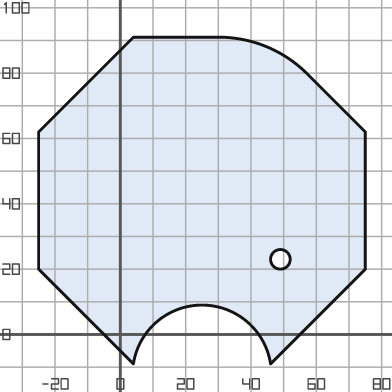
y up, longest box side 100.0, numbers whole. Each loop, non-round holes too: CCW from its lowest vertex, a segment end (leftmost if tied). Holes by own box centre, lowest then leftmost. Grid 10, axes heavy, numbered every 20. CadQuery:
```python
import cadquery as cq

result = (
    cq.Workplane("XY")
    .moveTo(4.0, -9.0)
    .threePointArc((25.0, 9.0), (46.0, -9.0))
    .lineTo(75.0, 20.0)
    .lineTo(75.0, 62.0)
    .lineTo(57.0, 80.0)
    .threePointArc((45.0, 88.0), (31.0, 91.0))
    .lineTo(4.0, 91.0)
    .lineTo(-25.0, 62.0)
    .lineTo(-25.0, 20.0)
    .close()
    .moveTo(49.0, 23.0)
    .circle(3.0)
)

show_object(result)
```